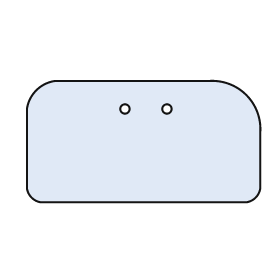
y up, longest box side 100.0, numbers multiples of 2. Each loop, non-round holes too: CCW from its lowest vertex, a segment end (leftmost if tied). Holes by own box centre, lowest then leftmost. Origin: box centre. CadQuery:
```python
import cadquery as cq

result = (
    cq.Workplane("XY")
    .moveTo(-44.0, -26.0)
    .lineTo(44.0, -26.0)
    .threePointArc((48.0, -24.0), (50.0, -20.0))
    .lineTo(50.0, 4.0)
    .threePointArc((44.0, 20.0), (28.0, 26.0))
    .lineTo(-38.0, 26.0)
    .threePointArc((-46.0, 22.0), (-50.0, 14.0))
    .lineTo(-50.0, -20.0)
    .threePointArc((-48.0, -24.0), (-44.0, -26.0))
    .close()
    .moveTo(-8.0, 14.0)
    .circle(2.0)
    .moveTo(10.0, 14.0)
    .circle(2.0)
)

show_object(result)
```